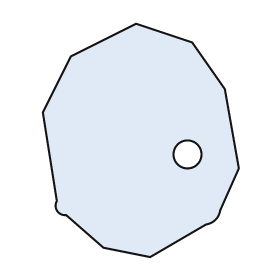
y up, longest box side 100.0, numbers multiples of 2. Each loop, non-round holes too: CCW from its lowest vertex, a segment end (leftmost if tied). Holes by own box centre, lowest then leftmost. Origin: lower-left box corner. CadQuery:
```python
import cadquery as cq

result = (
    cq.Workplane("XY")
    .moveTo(46.0, 0.0)
    .lineTo(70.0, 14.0)
    .threePointArc((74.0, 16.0), (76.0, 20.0))
    .lineTo(84.0, 38.0)
    .lineTo(78.0, 72.0)
    .lineTo(64.0, 92.0)
    .lineTo(40.0, 100.0)
    .lineTo(12.0, 86.0)
    .lineTo(0.0, 62.0)
    .lineTo(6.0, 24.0)
    .threePointArc((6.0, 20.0), (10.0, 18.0))
    .lineTo(26.0, 4.0)
    .close()
    .moveTo(62.0, 44.0)
    .circle(6.0)
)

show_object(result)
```